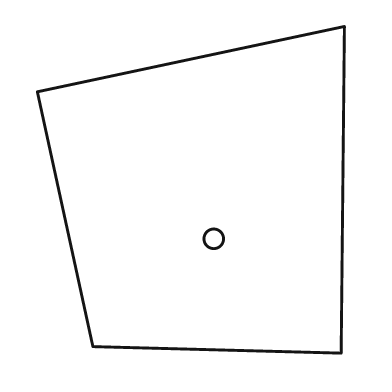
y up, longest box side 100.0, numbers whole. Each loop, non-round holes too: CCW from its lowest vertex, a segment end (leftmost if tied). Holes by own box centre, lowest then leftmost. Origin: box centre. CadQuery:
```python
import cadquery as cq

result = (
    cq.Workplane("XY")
    .moveTo(46.0, -50.0)
    .lineTo(47.0, 50.0)
    .lineTo(-47.0, 30.0)
    .lineTo(-30.0, -48.0)
    .close()
    .moveTo(7.0, -15.0)
    .circle(3.0)
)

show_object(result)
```